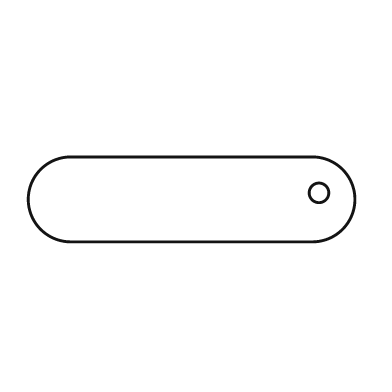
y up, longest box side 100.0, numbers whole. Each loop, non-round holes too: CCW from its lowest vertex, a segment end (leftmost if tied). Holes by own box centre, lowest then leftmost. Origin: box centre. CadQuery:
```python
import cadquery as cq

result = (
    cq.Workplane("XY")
    .moveTo(-37.0, -13.0)
    .lineTo(37.0, -13.0)
    .threePointArc((50.0, 0.0), (37.0, 13.0))
    .lineTo(-37.0, 13.0)
    .threePointArc((-50.0, 0.0), (-37.0, -13.0))
    .close()
    .moveTo(39.0, 2.0)
    .circle(3.0)
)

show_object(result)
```